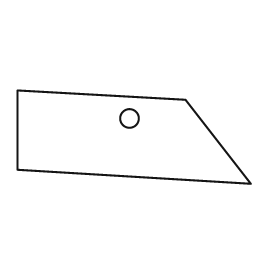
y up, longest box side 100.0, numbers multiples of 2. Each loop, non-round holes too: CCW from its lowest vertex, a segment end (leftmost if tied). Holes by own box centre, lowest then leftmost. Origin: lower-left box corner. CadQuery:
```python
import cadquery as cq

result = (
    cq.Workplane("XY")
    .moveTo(100.0, 0.0)
    .lineTo(72.0, 36.0)
    .lineTo(0.0, 40.0)
    .lineTo(0.0, 6.0)
    .close()
    .moveTo(48.0, 28.0)
    .circle(4.0)
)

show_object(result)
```